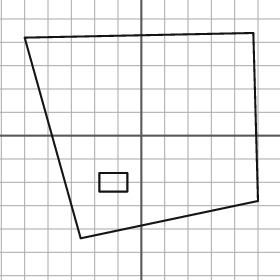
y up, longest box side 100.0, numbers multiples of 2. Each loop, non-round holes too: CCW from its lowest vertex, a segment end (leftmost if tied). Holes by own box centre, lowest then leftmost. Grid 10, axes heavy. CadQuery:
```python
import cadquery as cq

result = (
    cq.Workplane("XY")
    .moveTo(-26.0, -44.0)
    .lineTo(50.0, -28.0)
    .lineTo(48.0, 44.0)
    .lineTo(-50.0, 42.0)
    .close()
    .moveTo(-18.0, -24.0)
    .lineTo(-6.0, -24.0)
    .lineTo(-6.0, -16.0)
    .lineTo(-18.0, -16.0)
    .close()
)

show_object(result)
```